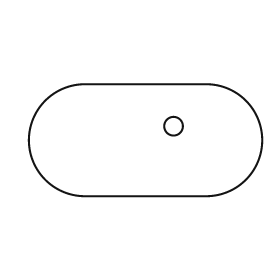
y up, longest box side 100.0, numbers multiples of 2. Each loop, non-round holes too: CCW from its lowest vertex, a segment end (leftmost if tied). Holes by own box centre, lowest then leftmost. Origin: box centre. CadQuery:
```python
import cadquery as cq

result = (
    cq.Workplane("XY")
    .moveTo(-26.0, -24.0)
    .lineTo(26.0, -24.0)
    .threePointArc((50.0, 0.0), (26.0, 24.0))
    .lineTo(-26.0, 24.0)
    .threePointArc((-50.0, 0.0), (-26.0, -24.0))
    .close()
    .moveTo(12.0, 6.0)
    .circle(4.0)
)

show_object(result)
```